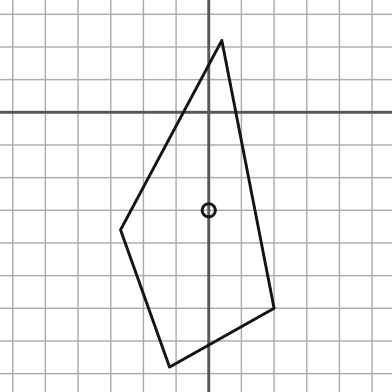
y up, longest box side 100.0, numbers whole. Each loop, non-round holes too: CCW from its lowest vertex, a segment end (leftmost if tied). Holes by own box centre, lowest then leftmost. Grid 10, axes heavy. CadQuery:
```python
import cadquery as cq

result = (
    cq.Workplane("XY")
    .moveTo(-12.0, -78.0)
    .lineTo(20.0, -60.0)
    .lineTo(4.0, 22.0)
    .lineTo(-27.0, -36.0)
    .close()
    .moveTo(0.0, -30.0)
    .circle(2.0)
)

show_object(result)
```